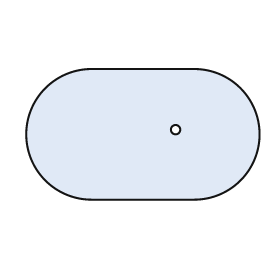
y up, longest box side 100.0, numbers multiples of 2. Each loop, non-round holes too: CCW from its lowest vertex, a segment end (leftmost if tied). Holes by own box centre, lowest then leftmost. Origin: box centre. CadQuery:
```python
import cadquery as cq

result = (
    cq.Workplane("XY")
    .moveTo(-22.0, -28.0)
    .lineTo(22.0, -28.0)
    .threePointArc((50.0, 0.0), (22.0, 28.0))
    .lineTo(-22.0, 28.0)
    .threePointArc((-50.0, 0.0), (-22.0, -28.0))
    .close()
    .moveTo(14.0, 2.0)
    .circle(2.0)
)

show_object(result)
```